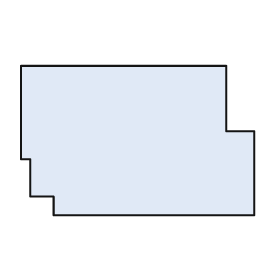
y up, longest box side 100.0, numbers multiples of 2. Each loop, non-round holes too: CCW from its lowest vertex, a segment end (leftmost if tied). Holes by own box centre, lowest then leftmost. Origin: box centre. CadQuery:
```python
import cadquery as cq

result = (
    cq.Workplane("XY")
    .moveTo(-36.0, -32.0)
    .lineTo(50.0, -32.0)
    .lineTo(50.0, 4.0)
    .lineTo(38.0, 4.0)
    .lineTo(38.0, 32.0)
    .lineTo(-50.0, 32.0)
    .lineTo(-50.0, -8.0)
    .lineTo(-46.0, -8.0)
    .lineTo(-46.0, -24.0)
    .lineTo(-36.0, -24.0)
    .close()
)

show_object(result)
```